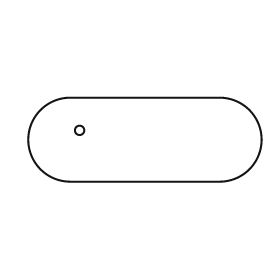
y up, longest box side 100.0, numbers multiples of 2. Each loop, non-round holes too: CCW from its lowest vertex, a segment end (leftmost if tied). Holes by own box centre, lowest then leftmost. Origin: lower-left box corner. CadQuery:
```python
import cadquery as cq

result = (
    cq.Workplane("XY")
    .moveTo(18.0, 0.0)
    .lineTo(82.0, 0.0)
    .threePointArc((100.0, 18.0), (82.0, 36.0))
    .lineTo(18.0, 36.0)
    .threePointArc((0.0, 18.0), (18.0, 0.0))
    .close()
    .moveTo(22.0, 22.0)
    .circle(2.0)
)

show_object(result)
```